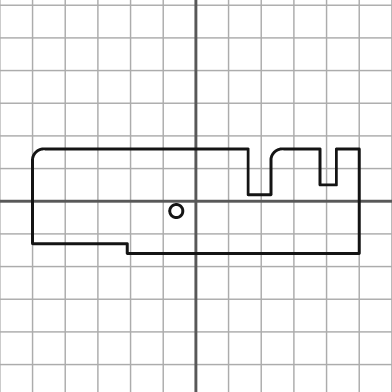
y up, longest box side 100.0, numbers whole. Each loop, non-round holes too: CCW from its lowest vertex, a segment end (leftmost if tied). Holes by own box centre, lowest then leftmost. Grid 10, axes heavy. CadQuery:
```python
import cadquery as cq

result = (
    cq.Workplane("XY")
    .moveTo(-21.0, -16.0)
    .lineTo(50.0, -16.0)
    .lineTo(50.0, 16.0)
    .lineTo(43.0, 16.0)
    .lineTo(43.0, 5.0)
    .lineTo(38.0, 5.0)
    .lineTo(38.0, 16.0)
    .lineTo(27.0, 16.0)
    .threePointArc((24.0, 15.0), (23.0, 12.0))
    .lineTo(23.0, 2.0)
    .lineTo(16.0, 2.0)
    .lineTo(16.0, 16.0)
    .lineTo(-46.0, 16.0)
    .threePointArc((-49.0, 15.0), (-50.0, 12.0))
    .lineTo(-50.0, -13.0)
    .lineTo(-21.0, -13.0)
    .close()
    .moveTo(-6.0, -3.0)
    .circle(2.0)
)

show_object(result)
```